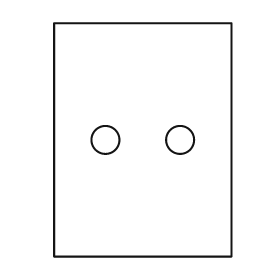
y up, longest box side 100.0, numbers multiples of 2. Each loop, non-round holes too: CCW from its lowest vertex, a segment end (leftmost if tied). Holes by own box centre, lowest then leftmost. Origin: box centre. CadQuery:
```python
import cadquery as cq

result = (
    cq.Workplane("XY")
    .moveTo(-38.0, -50.0)
    .lineTo(38.0, -50.0)
    .lineTo(38.0, 50.0)
    .lineTo(-38.0, 50.0)
    .close()
    .moveTo(-16.0, 0.0)
    .circle(6.0)
    .moveTo(16.0, 0.0)
    .circle(6.0)
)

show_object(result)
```